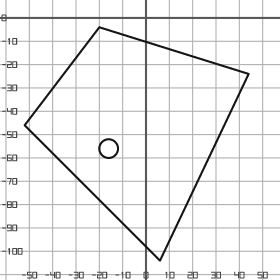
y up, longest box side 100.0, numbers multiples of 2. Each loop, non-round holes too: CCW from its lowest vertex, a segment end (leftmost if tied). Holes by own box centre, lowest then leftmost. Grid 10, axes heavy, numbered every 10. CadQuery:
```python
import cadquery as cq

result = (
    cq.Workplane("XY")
    .moveTo(6.0, -104.0)
    .lineTo(44.0, -24.0)
    .lineTo(-20.0, -4.0)
    .lineTo(-52.0, -46.0)
    .close()
    .moveTo(-16.0, -56.0)
    .circle(4.0)
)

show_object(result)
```